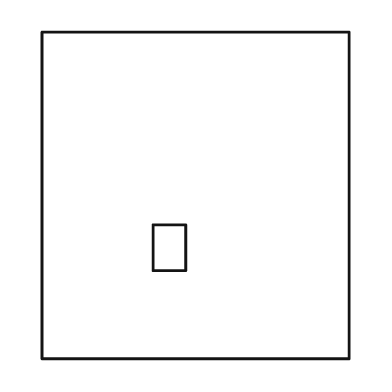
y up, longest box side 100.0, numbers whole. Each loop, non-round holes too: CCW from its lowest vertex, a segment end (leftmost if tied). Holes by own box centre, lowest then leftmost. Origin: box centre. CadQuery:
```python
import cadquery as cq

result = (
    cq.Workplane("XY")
    .moveTo(-47.0, -50.0)
    .lineTo(47.0, -50.0)
    .lineTo(47.0, 50.0)
    .lineTo(-47.0, 50.0)
    .close()
    .moveTo(-13.0, -23.0)
    .lineTo(-3.0, -23.0)
    .lineTo(-3.0, -9.0)
    .lineTo(-13.0, -9.0)
    .close()
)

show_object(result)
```